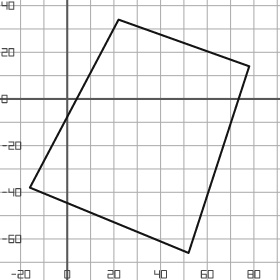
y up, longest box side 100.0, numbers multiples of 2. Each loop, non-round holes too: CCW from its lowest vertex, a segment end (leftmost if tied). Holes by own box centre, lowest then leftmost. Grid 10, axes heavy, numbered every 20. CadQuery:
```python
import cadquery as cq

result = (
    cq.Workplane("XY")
    .moveTo(52.0, -66.0)
    .lineTo(78.0, 14.0)
    .lineTo(22.0, 34.0)
    .lineTo(-16.0, -38.0)
    .close()
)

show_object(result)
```